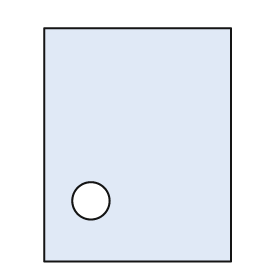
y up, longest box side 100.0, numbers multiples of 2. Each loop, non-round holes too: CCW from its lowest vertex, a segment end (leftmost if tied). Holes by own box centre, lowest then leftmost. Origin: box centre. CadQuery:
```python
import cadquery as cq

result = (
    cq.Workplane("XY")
    .moveTo(-40.0, -50.0)
    .lineTo(40.0, -50.0)
    .lineTo(40.0, 50.0)
    .lineTo(-40.0, 50.0)
    .close()
    .moveTo(-20.0, -24.0)
    .circle(8.0)
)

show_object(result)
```